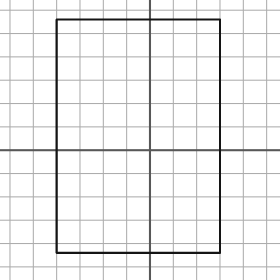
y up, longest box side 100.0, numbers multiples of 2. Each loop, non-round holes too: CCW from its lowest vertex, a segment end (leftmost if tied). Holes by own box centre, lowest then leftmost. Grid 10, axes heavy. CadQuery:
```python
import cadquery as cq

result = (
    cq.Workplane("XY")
    .moveTo(-40.0, -44.0)
    .lineTo(30.0, -44.0)
    .lineTo(30.0, 56.0)
    .lineTo(-40.0, 56.0)
    .close()
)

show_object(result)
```